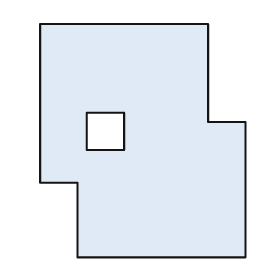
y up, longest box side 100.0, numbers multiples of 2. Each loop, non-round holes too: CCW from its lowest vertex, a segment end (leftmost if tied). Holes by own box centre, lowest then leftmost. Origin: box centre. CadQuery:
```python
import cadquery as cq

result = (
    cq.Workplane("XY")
    .moveTo(-28.0, -50.0)
    .lineTo(44.0, -50.0)
    .lineTo(44.0, 8.0)
    .lineTo(28.0, 8.0)
    .lineTo(28.0, 50.0)
    .lineTo(-44.0, 50.0)
    .lineTo(-44.0, -18.0)
    .lineTo(-28.0, -18.0)
    .close()
    .moveTo(-24.0, -4.0)
    .lineTo(-8.0, -4.0)
    .lineTo(-8.0, 12.0)
    .lineTo(-24.0, 12.0)
    .close()
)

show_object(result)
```